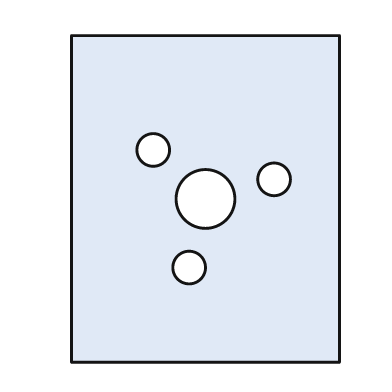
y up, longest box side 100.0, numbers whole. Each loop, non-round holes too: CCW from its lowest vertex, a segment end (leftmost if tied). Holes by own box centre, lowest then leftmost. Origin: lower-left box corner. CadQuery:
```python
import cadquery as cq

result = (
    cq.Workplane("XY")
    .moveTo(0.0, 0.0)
    .lineTo(82.0, 0.0)
    .lineTo(82.0, 100.0)
    .lineTo(0.0, 100.0)
    .close()
    .moveTo(36.0, 29.0)
    .circle(5.0)
    .moveTo(41.0, 50.0)
    .circle(9.0)
    .moveTo(62.0, 56.0)
    .circle(5.0)
    .moveTo(25.0, 65.0)
    .circle(5.0)
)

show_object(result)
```